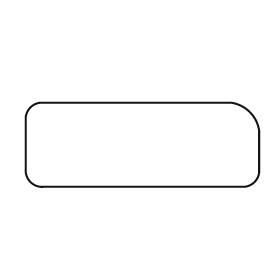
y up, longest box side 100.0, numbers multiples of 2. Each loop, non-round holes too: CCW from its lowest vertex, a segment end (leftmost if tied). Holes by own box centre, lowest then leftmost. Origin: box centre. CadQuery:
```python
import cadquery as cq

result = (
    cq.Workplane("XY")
    .moveTo(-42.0, -18.0)
    .lineTo(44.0, -18.0)
    .threePointArc((48.0, -16.0), (50.0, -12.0))
    .lineTo(50.0, 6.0)
    .threePointArc((46.0, 14.0), (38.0, 18.0))
    .lineTo(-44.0, 18.0)
    .threePointArc((-48.0, 16.0), (-50.0, 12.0))
    .lineTo(-50.0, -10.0)
    .threePointArc((-48.0, -16.0), (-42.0, -18.0))
    .close()
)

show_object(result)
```